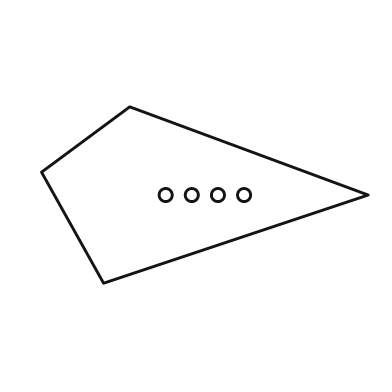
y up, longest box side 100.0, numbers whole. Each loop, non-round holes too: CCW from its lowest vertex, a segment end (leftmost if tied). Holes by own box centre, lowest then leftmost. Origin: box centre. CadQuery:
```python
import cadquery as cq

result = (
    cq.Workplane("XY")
    .moveTo(-31.0, -27.0)
    .lineTo(50.0, 0.0)
    .lineTo(-23.0, 27.0)
    .lineTo(-50.0, 7.0)
    .close()
    .moveTo(-12.0, 0.0)
    .circle(2.0)
    .moveTo(-4.0, 0.0)
    .circle(2.0)
    .moveTo(4.0, 0.0)
    .circle(2.0)
    .moveTo(12.0, 0.0)
    .circle(2.0)
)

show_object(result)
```